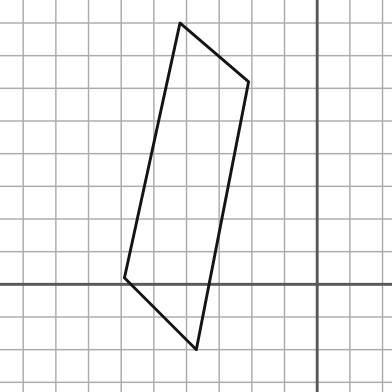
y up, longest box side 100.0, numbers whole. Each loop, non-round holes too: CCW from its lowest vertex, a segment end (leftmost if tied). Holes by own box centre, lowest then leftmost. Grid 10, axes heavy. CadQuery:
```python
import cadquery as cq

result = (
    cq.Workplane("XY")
    .moveTo(-37.0, -20.0)
    .lineTo(-21.0, 62.0)
    .lineTo(-42.0, 80.0)
    .lineTo(-59.0, 2.0)
    .close()
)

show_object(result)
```